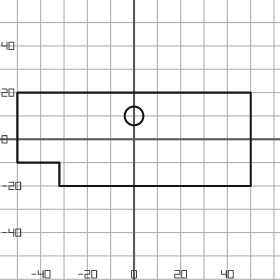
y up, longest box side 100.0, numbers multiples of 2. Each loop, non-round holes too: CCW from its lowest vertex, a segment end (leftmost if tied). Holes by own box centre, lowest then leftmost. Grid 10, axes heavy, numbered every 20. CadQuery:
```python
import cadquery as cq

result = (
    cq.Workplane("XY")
    .moveTo(-32.0, -20.0)
    .lineTo(50.0, -20.0)
    .lineTo(50.0, 20.0)
    .lineTo(-50.0, 20.0)
    .lineTo(-50.0, -10.0)
    .lineTo(-32.0, -10.0)
    .close()
    .moveTo(0.0, 10.0)
    .circle(4.0)
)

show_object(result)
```